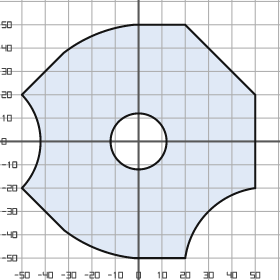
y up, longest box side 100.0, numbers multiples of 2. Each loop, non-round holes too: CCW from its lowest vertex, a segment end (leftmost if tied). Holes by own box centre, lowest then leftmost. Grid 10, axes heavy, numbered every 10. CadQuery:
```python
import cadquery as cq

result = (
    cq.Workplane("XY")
    .moveTo(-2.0, -50.0)
    .lineTo(20.0, -50.0)
    .threePointArc((30.0, -30.0), (50.0, -20.0))
    .lineTo(50.0, 20.0)
    .lineTo(20.0, 50.0)
    .lineTo(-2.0, 50.0)
    .threePointArc((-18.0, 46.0), (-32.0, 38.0))
    .lineTo(-50.0, 20.0)
    .threePointArc((-42.0, 0.0), (-50.0, -20.0))
    .lineTo(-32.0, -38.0)
    .threePointArc((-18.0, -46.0), (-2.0, -50.0))
    .close()
    .moveTo(0.0, 0.0)
    .circle(12.0)
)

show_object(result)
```